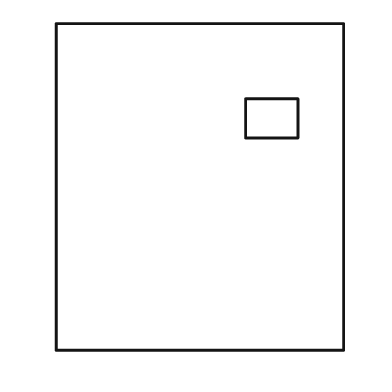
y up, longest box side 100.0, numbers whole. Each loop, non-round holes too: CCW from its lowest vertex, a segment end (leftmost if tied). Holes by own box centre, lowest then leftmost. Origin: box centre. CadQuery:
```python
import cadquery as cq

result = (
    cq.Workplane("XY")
    .moveTo(-44.0, -50.0)
    .lineTo(44.0, -50.0)
    .lineTo(44.0, 50.0)
    .lineTo(-44.0, 50.0)
    .close()
    .moveTo(14.0, 15.0)
    .lineTo(30.0, 15.0)
    .lineTo(30.0, 27.0)
    .lineTo(14.0, 27.0)
    .close()
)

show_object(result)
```